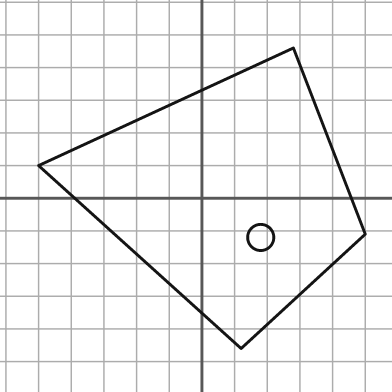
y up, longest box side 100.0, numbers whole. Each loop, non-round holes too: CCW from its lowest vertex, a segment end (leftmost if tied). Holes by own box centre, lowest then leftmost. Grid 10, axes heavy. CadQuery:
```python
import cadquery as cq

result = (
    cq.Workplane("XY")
    .moveTo(12.0, -46.0)
    .lineTo(50.0, -11.0)
    .lineTo(28.0, 46.0)
    .lineTo(-50.0, 10.0)
    .close()
    .moveTo(18.0, -12.0)
    .circle(4.0)
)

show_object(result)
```